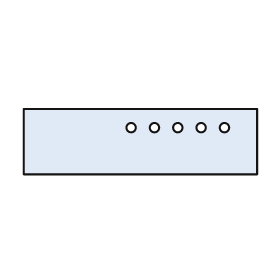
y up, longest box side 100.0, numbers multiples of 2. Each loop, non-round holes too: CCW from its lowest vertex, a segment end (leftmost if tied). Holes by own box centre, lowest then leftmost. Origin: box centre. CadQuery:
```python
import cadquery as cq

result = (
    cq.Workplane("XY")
    .moveTo(-50.0, -14.0)
    .lineTo(50.0, -14.0)
    .lineTo(50.0, 14.0)
    .lineTo(-50.0, 14.0)
    .close()
    .moveTo(-4.0, 6.0)
    .circle(2.0)
    .moveTo(6.0, 6.0)
    .circle(2.0)
    .moveTo(16.0, 6.0)
    .circle(2.0)
    .moveTo(26.0, 6.0)
    .circle(2.0)
    .moveTo(36.0, 6.0)
    .circle(2.0)
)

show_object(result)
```